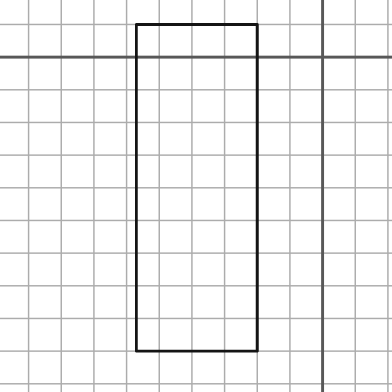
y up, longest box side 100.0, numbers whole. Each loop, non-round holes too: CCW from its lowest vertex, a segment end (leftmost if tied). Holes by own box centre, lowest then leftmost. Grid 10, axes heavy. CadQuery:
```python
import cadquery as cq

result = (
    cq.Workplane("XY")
    .moveTo(-57.0, -90.0)
    .lineTo(-20.0, -90.0)
    .lineTo(-20.0, 10.0)
    .lineTo(-57.0, 10.0)
    .close()
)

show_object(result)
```